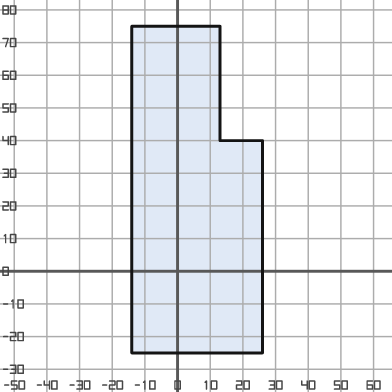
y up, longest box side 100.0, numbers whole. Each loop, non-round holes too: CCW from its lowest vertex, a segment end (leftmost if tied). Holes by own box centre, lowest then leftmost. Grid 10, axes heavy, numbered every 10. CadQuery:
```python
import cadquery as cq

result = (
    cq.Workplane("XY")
    .moveTo(-14.0, -25.0)
    .lineTo(26.0, -25.0)
    .lineTo(26.0, 40.0)
    .lineTo(13.0, 40.0)
    .lineTo(13.0, 75.0)
    .lineTo(-14.0, 75.0)
    .close()
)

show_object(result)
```